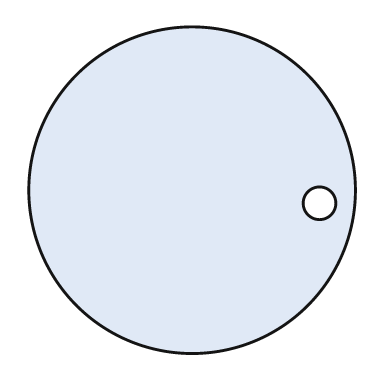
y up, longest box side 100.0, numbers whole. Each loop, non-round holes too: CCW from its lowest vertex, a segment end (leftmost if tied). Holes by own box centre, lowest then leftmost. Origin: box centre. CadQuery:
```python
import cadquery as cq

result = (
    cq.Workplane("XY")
    .moveTo(0.0, 0.0)
    .circle(50.0)
    .moveTo(39.0, -4.0)
    .circle(5.0)
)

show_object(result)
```